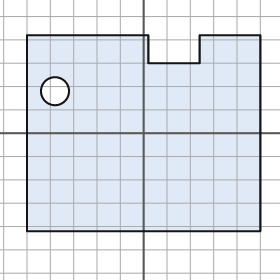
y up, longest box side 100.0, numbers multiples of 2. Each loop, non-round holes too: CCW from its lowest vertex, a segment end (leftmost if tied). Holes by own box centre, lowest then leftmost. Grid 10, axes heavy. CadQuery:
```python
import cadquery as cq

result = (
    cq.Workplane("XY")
    .moveTo(-50.0, -42.0)
    .lineTo(50.0, -42.0)
    .lineTo(50.0, 42.0)
    .lineTo(24.0, 42.0)
    .lineTo(24.0, 30.0)
    .lineTo(2.0, 30.0)
    .lineTo(2.0, 42.0)
    .lineTo(-50.0, 42.0)
    .close()
    .moveTo(-38.0, 18.0)
    .circle(6.0)
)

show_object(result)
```